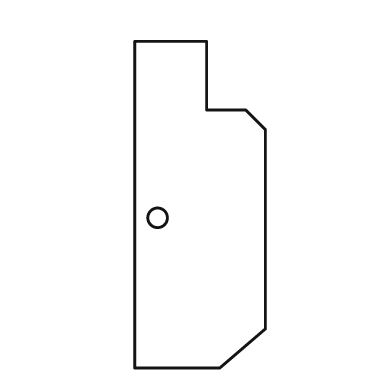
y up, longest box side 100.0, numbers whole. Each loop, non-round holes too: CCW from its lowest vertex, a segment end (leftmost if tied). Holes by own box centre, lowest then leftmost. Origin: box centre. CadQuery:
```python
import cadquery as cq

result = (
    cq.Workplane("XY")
    .moveTo(-20.0, -50.0)
    .lineTo(6.0, -50.0)
    .lineTo(20.0, -38.0)
    .lineTo(20.0, 23.0)
    .lineTo(14.0, 29.0)
    .lineTo(2.0, 29.0)
    .lineTo(2.0, 50.0)
    .lineTo(-20.0, 50.0)
    .close()
    .moveTo(-13.0, -4.0)
    .circle(3.0)
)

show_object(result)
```